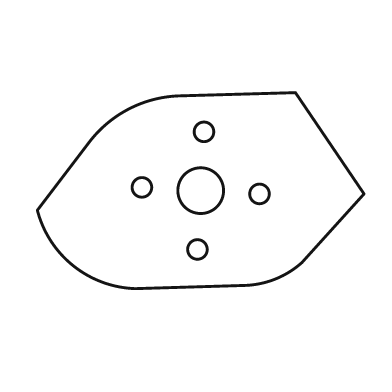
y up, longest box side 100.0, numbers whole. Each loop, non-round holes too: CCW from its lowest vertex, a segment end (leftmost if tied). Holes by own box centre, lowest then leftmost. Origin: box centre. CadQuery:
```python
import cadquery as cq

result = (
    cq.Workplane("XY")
    .moveTo(-20.0, -30.0)
    .lineTo(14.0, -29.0)
    .threePointArc((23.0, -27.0), (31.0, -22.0))
    .lineTo(50.0, -1.0)
    .lineTo(29.0, 30.0)
    .lineTo(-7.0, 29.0)
    .threePointArc((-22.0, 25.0), (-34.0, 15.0))
    .lineTo(-50.0, -6.0)
    .threePointArc((-39.0, -23.0), (-20.0, -30.0))
    .close()
    .moveTo(-1.0, -18.0)
    .circle(3.0)
    .moveTo(18.0, -1.0)
    .circle(3.0)
    .moveTo(0.0, 0.0)
    .circle(7.0)
    .moveTo(-18.0, 1.0)
    .circle(3.0)
    .moveTo(1.0, 18.0)
    .circle(3.0)
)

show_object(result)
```